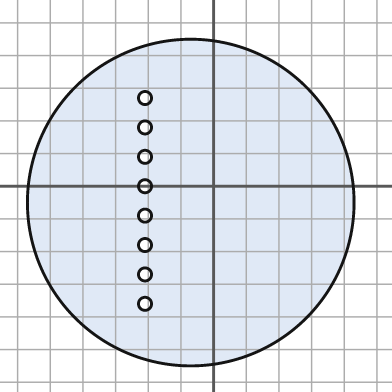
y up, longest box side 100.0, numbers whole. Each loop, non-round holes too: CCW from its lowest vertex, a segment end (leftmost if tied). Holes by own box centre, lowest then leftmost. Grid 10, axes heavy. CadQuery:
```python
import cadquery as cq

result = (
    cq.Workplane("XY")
    .moveTo(-7.0, -5.0)
    .circle(50.0)
    .moveTo(-21.0, -36.0)
    .circle(2.0)
    .moveTo(-21.0, -27.0)
    .circle(2.0)
    .moveTo(-21.0, -18.0)
    .circle(2.0)
    .moveTo(-21.0, -9.0)
    .circle(2.0)
    .moveTo(-21.0, 0.0)
    .circle(2.0)
    .moveTo(-21.0, 9.0)
    .circle(2.0)
    .moveTo(-21.0, 18.0)
    .circle(2.0)
    .moveTo(-21.0, 27.0)
    .circle(2.0)
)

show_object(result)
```